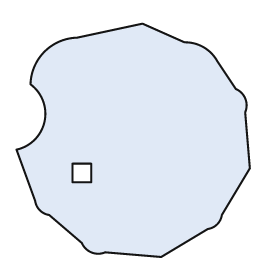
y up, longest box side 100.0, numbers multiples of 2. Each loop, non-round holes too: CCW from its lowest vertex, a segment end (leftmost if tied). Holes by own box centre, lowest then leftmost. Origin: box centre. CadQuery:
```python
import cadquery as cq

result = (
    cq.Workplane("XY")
    .moveTo(12.0, -50.0)
    .lineTo(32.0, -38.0)
    .threePointArc((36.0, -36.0), (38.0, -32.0))
    .lineTo(50.0, -12.0)
    .lineTo(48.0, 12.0)
    .threePointArc((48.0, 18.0), (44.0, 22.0))
    .lineTo(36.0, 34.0)
    .threePointArc((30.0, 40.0), (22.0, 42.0))
    .lineTo(4.0, 50.0)
    .lineTo(-24.0, 44.0)
    .threePointArc((-38.0, 38.0), (-44.0, 24.0))
    .threePointArc((-38.0, 8.0), (-50.0, -4.0))
    .lineTo(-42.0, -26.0)
    .threePointArc((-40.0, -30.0), (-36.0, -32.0))
    .lineTo(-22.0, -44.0)
    .threePointArc((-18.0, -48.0), (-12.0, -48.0))
    .close()
    .moveTo(-26.0, -18.0)
    .lineTo(-18.0, -18.0)
    .lineTo(-18.0, -10.0)
    .lineTo(-26.0, -10.0)
    .close()
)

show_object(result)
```